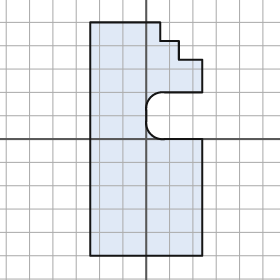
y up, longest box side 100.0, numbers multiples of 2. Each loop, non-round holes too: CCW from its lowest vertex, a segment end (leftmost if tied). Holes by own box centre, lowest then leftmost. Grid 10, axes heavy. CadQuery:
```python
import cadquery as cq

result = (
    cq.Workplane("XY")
    .moveTo(-24.0, -50.0)
    .lineTo(24.0, -50.0)
    .lineTo(24.0, 0.0)
    .lineTo(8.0, 0.0)
    .threePointArc((2.0, 2.0), (0.0, 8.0))
    .lineTo(0.0, 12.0)
    .threePointArc((2.0, 18.0), (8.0, 20.0))
    .lineTo(24.0, 20.0)
    .lineTo(24.0, 34.0)
    .lineTo(14.0, 34.0)
    .lineTo(14.0, 42.0)
    .lineTo(6.0, 42.0)
    .lineTo(6.0, 50.0)
    .lineTo(-24.0, 50.0)
    .close()
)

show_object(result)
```